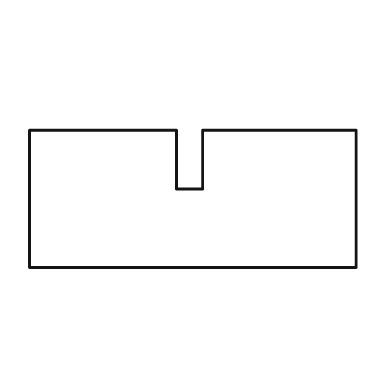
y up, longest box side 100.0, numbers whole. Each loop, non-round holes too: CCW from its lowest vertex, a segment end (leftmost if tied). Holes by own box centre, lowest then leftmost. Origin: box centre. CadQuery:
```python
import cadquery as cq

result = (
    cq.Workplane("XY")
    .moveTo(-50.0, -21.0)
    .lineTo(50.0, -21.0)
    .lineTo(50.0, 21.0)
    .lineTo(3.0, 21.0)
    .lineTo(3.0, 3.0)
    .lineTo(-5.0, 3.0)
    .lineTo(-5.0, 21.0)
    .lineTo(-50.0, 21.0)
    .close()
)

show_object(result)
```